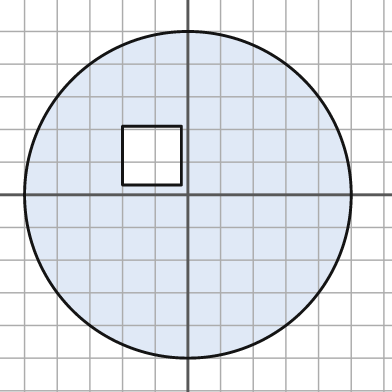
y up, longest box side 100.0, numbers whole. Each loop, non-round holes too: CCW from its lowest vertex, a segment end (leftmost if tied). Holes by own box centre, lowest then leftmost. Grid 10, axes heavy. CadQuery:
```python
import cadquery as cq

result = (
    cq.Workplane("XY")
    .moveTo(0.0, 0.0)
    .circle(50.0)
    .moveTo(-20.0, 3.0)
    .lineTo(-2.0, 3.0)
    .lineTo(-2.0, 21.0)
    .lineTo(-20.0, 21.0)
    .close()
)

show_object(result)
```